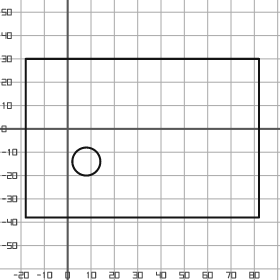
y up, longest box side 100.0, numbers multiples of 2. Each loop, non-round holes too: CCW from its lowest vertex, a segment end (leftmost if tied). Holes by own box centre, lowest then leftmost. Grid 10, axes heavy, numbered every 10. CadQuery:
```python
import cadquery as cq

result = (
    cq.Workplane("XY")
    .moveTo(-18.0, -38.0)
    .lineTo(82.0, -38.0)
    .lineTo(82.0, 30.0)
    .lineTo(-18.0, 30.0)
    .close()
    .moveTo(8.0, -14.0)
    .circle(6.0)
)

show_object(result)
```